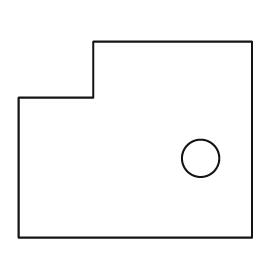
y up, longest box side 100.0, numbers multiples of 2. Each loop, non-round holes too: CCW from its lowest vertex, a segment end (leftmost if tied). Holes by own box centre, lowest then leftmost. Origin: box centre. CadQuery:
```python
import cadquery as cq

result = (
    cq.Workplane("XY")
    .moveTo(-50.0, -42.0)
    .lineTo(50.0, -42.0)
    .lineTo(50.0, 42.0)
    .lineTo(-18.0, 42.0)
    .lineTo(-18.0, 18.0)
    .lineTo(-50.0, 18.0)
    .close()
    .moveTo(28.0, -8.0)
    .circle(8.0)
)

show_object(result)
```